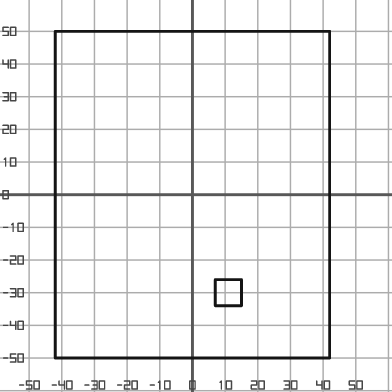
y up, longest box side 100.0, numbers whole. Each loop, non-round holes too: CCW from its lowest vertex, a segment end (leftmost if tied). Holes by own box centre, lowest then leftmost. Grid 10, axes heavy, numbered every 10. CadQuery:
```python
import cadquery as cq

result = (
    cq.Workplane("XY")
    .moveTo(-42.0, -50.0)
    .lineTo(42.0, -50.0)
    .lineTo(42.0, 50.0)
    .lineTo(-42.0, 50.0)
    .close()
    .moveTo(7.0, -34.0)
    .lineTo(15.0, -34.0)
    .lineTo(15.0, -26.0)
    .lineTo(7.0, -26.0)
    .close()
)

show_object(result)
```